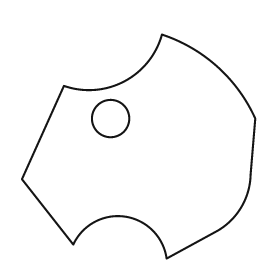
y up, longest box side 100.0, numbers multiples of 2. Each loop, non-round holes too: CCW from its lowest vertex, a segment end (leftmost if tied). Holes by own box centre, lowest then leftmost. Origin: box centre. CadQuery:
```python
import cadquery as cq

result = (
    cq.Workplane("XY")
    .moveTo(12.0, -48.0)
    .lineTo(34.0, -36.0)
    .threePointArc((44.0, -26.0), (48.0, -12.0))
    .lineTo(50.0, 12.0)
    .threePointArc((34.0, 34.0), (10.0, 48.0))
    .threePointArc((-6.0, 28.0), (-32.0, 26.0))
    .lineTo(-50.0, -14.0)
    .lineTo(-28.0, -42.0)
    .threePointArc((-6.0, -30.0), (12.0, -48.0))
    .close()
    .moveTo(-12.0, 12.0)
    .circle(8.0)
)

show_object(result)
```